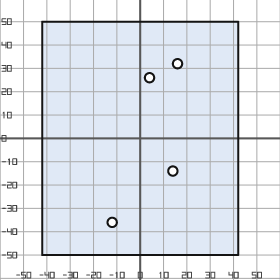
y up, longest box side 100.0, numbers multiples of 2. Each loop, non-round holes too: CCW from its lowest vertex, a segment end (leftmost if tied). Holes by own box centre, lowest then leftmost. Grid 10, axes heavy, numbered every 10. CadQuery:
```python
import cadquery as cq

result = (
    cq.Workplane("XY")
    .moveTo(-42.0, -50.0)
    .lineTo(42.0, -50.0)
    .lineTo(42.0, 50.0)
    .lineTo(-42.0, 50.0)
    .close()
    .moveTo(-12.0, -36.0)
    .circle(2.0)
    .moveTo(14.0, -14.0)
    .circle(2.0)
    .moveTo(4.0, 26.0)
    .circle(2.0)
    .moveTo(16.0, 32.0)
    .circle(2.0)
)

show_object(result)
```